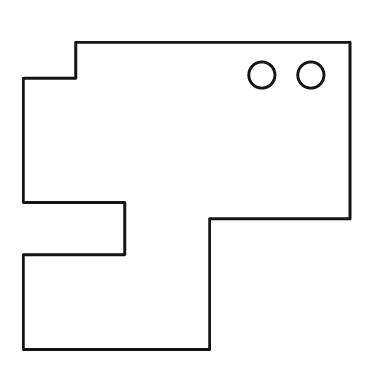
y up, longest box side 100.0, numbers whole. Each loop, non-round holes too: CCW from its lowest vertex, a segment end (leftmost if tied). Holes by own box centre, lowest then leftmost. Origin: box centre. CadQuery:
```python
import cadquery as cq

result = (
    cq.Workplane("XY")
    .moveTo(-50.0, -47.0)
    .lineTo(7.0, -47.0)
    .lineTo(7.0, -7.0)
    .lineTo(50.0, -7.0)
    .lineTo(50.0, 47.0)
    .lineTo(-34.0, 47.0)
    .lineTo(-34.0, 36.0)
    .lineTo(-50.0, 36.0)
    .lineTo(-50.0, -2.0)
    .lineTo(-19.0, -2.0)
    .lineTo(-19.0, -18.0)
    .lineTo(-50.0, -18.0)
    .close()
    .moveTo(23.0, 37.0)
    .circle(4.0)
    .moveTo(38.0, 37.0)
    .circle(4.0)
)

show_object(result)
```